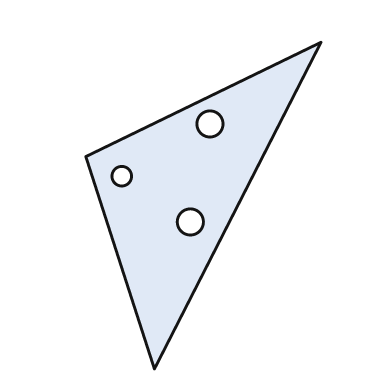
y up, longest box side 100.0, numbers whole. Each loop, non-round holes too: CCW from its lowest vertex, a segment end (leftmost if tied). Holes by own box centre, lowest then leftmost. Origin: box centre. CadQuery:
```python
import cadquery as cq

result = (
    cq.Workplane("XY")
    .moveTo(-15.0, -50.0)
    .lineTo(36.0, 50.0)
    .lineTo(-36.0, 15.0)
    .close()
    .moveTo(-4.0, -5.0)
    .circle(4.0)
    .moveTo(-25.0, 9.0)
    .circle(3.0)
    .moveTo(2.0, 25.0)
    .circle(4.0)
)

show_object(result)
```